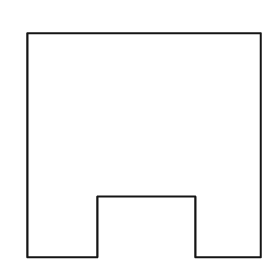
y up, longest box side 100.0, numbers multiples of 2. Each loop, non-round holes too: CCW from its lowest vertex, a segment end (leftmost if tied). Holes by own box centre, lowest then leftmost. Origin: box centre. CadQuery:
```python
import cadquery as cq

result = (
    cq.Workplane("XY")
    .moveTo(-50.0, -48.0)
    .lineTo(-20.0, -48.0)
    .lineTo(-20.0, -22.0)
    .lineTo(22.0, -22.0)
    .lineTo(22.0, -48.0)
    .lineTo(50.0, -48.0)
    .lineTo(50.0, 48.0)
    .lineTo(-50.0, 48.0)
    .close()
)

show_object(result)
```